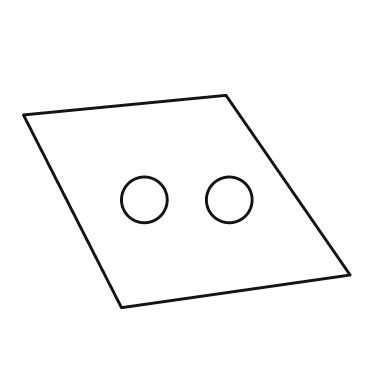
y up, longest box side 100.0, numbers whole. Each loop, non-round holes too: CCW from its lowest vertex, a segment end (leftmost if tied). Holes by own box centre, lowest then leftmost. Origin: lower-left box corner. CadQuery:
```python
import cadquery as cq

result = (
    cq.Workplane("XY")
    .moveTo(30.0, 0.0)
    .lineTo(100.0, 10.0)
    .lineTo(62.0, 65.0)
    .lineTo(0.0, 59.0)
    .close()
    .moveTo(37.0, 33.0)
    .circle(7.0)
    .moveTo(63.0, 33.0)
    .circle(7.0)
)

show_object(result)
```